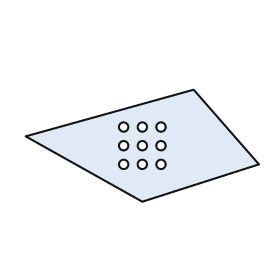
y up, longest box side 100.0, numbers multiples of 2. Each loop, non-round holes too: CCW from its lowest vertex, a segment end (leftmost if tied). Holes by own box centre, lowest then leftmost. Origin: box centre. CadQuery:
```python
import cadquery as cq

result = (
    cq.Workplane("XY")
    .moveTo(0.0, -24.0)
    .lineTo(50.0, -8.0)
    .lineTo(22.0, 24.0)
    .lineTo(-50.0, 4.0)
    .close()
    .moveTo(-8.0, -8.0)
    .circle(2.0)
    .moveTo(0.0, -8.0)
    .circle(2.0)
    .moveTo(8.0, -8.0)
    .circle(2.0)
    .moveTo(-8.0, 0.0)
    .circle(2.0)
    .moveTo(0.0, 0.0)
    .circle(2.0)
    .moveTo(8.0, 0.0)
    .circle(2.0)
    .moveTo(-8.0, 8.0)
    .circle(2.0)
    .moveTo(0.0, 8.0)
    .circle(2.0)
    .moveTo(8.0, 8.0)
    .circle(2.0)
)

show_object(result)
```